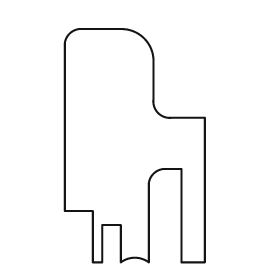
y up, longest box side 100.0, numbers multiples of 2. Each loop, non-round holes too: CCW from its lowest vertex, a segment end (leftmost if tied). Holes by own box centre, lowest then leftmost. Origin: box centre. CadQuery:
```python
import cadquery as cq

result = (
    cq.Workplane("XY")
    .moveTo(-18.0, -50.0)
    .lineTo(-14.0, -50.0)
    .lineTo(-14.0, -34.0)
    .lineTo(-6.0, -34.0)
    .lineTo(-6.0, -50.0)
    .threePointArc((0.0, -48.0), (6.0, -50.0))
    .lineTo(6.0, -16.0)
    .threePointArc((8.0, -12.0), (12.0, -10.0))
    .lineTo(20.0, -10.0)
    .lineTo(20.0, -50.0)
    .lineTo(30.0, -50.0)
    .lineTo(30.0, 12.0)
    .lineTo(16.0, 12.0)
    .threePointArc((10.0, 14.0), (8.0, 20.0))
    .lineTo(8.0, 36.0)
    .threePointArc((4.0, 46.0), (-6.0, 50.0))
    .lineTo(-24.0, 50.0)
    .threePointArc((-28.0, 48.0), (-30.0, 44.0))
    .lineTo(-30.0, -28.0)
    .lineTo(-18.0, -28.0)
    .close()
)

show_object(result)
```